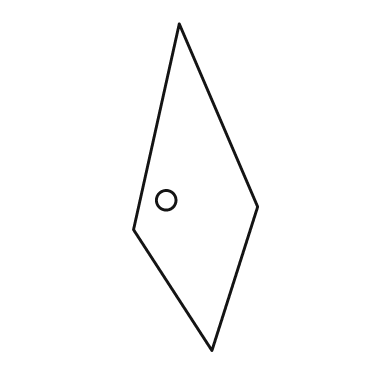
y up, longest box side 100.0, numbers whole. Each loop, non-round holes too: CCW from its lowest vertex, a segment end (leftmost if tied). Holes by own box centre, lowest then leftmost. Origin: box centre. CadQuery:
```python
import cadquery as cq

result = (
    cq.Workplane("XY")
    .moveTo(5.0, -50.0)
    .lineTo(19.0, -6.0)
    .lineTo(-5.0, 50.0)
    .lineTo(-19.0, -13.0)
    .close()
    .moveTo(-9.0, -4.0)
    .circle(3.0)
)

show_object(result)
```